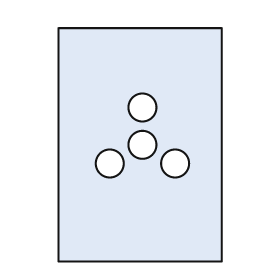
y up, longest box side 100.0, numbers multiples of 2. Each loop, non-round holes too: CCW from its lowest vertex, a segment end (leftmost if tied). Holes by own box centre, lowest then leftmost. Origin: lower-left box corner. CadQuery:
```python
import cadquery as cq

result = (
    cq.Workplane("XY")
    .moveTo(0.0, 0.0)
    .lineTo(70.0, 0.0)
    .lineTo(70.0, 100.0)
    .lineTo(0.0, 100.0)
    .close()
    .moveTo(22.0, 42.0)
    .circle(6.0)
    .moveTo(50.0, 42.0)
    .circle(6.0)
    .moveTo(36.0, 50.0)
    .circle(6.0)
    .moveTo(36.0, 66.0)
    .circle(6.0)
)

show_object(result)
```